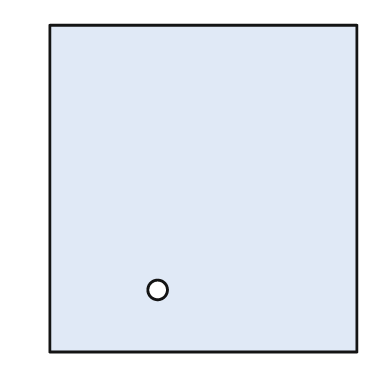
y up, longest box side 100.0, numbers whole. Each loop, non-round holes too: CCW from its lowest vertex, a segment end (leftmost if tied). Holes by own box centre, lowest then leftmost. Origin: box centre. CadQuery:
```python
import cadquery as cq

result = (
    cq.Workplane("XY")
    .moveTo(-47.0, -50.0)
    .lineTo(47.0, -50.0)
    .lineTo(47.0, 50.0)
    .lineTo(-47.0, 50.0)
    .close()
    .moveTo(-14.0, -31.0)
    .circle(3.0)
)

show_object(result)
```